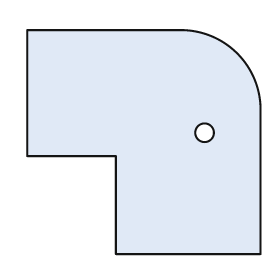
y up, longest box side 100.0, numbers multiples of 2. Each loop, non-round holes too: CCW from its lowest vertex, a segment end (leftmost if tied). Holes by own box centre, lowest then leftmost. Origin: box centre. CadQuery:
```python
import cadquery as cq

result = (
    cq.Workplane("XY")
    .moveTo(-12.0, -48.0)
    .lineTo(50.0, -48.0)
    .lineTo(50.0, 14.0)
    .threePointArc((40.0, 38.0), (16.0, 48.0))
    .lineTo(-50.0, 48.0)
    .lineTo(-50.0, -6.0)
    .lineTo(-12.0, -6.0)
    .close()
    .moveTo(26.0, 4.0)
    .circle(4.0)
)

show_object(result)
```